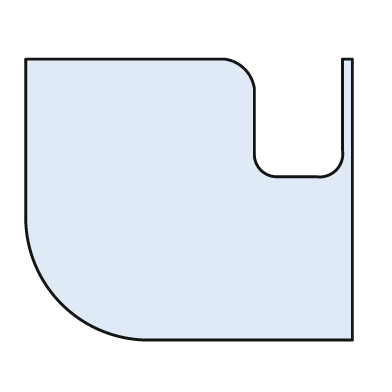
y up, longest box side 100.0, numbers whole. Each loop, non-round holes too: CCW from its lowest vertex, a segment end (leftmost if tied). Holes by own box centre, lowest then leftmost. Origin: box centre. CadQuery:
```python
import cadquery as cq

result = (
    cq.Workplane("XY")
    .moveTo(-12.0, -43.0)
    .lineTo(50.0, -43.0)
    .lineTo(50.0, 43.0)
    .lineTo(47.0, 43.0)
    .lineTo(47.0, 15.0)
    .threePointArc((45.0, 9.0), (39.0, 7.0))
    .lineTo(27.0, 7.0)
    .threePointArc((22.0, 9.0), (20.0, 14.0))
    .lineTo(20.0, 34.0)
    .threePointArc((17.0, 40.0), (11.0, 43.0))
    .lineTo(-50.0, 43.0)
    .lineTo(-50.0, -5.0)
    .threePointArc((-39.0, -32.0), (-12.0, -43.0))
    .close()
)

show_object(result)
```